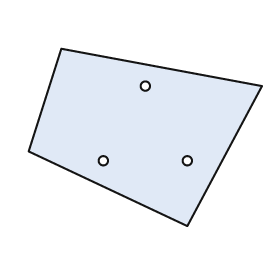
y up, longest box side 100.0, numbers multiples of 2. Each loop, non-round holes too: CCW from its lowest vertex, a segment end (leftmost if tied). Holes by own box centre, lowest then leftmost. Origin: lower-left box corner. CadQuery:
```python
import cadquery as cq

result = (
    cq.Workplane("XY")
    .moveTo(68.0, 0.0)
    .lineTo(100.0, 60.0)
    .lineTo(14.0, 76.0)
    .lineTo(0.0, 32.0)
    .close()
    .moveTo(32.0, 28.0)
    .circle(2.0)
    .moveTo(68.0, 28.0)
    .circle(2.0)
    .moveTo(50.0, 60.0)
    .circle(2.0)
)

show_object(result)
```